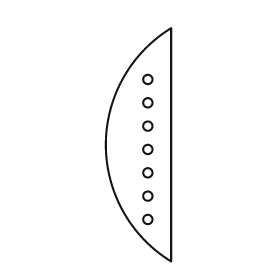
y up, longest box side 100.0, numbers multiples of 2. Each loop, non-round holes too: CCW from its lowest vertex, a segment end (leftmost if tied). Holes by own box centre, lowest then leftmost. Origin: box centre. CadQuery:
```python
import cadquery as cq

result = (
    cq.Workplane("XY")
    .moveTo(14.0, -50.0)
    .lineTo(14.0, 50.0)
    .threePointArc((-14.0, 0.0), (14.0, -50.0))
    .close()
    .moveTo(4.0, -32.0)
    .circle(2.0)
    .moveTo(4.0, -22.0)
    .circle(2.0)
    .moveTo(4.0, -12.0)
    .circle(2.0)
    .moveTo(4.0, -2.0)
    .circle(2.0)
    .moveTo(4.0, 8.0)
    .circle(2.0)
    .moveTo(4.0, 18.0)
    .circle(2.0)
    .moveTo(4.0, 28.0)
    .circle(2.0)
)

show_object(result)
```